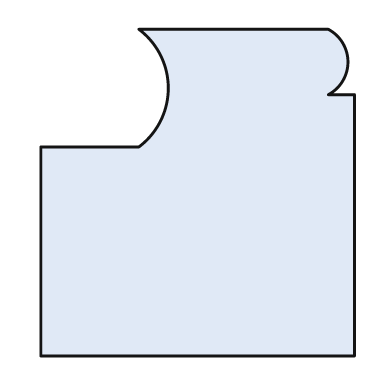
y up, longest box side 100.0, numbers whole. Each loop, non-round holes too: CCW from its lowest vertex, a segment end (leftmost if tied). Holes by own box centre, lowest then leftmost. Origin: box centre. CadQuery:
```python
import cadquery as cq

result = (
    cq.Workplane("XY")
    .moveTo(-48.0, -50.0)
    .lineTo(48.0, -50.0)
    .lineTo(48.0, 30.0)
    .lineTo(40.0, 30.0)
    .threePointArc((46.0, 40.0), (40.0, 50.0))
    .lineTo(-18.0, 50.0)
    .threePointArc((-9.0, 32.0), (-18.0, 14.0))
    .lineTo(-48.0, 14.0)
    .close()
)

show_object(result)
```